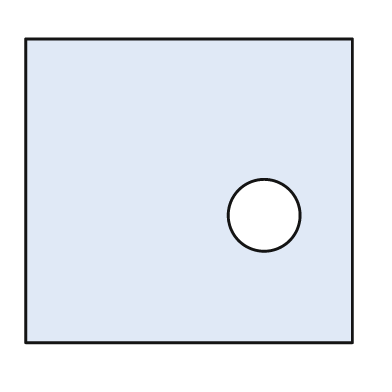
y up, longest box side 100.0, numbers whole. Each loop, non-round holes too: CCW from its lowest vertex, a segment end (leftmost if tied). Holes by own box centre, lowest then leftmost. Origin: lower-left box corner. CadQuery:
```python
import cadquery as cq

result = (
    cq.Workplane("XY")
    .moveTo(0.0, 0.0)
    .lineTo(100.0, 0.0)
    .lineTo(100.0, 93.0)
    .lineTo(0.0, 93.0)
    .close()
    .moveTo(73.0, 39.0)
    .circle(11.0)
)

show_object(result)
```